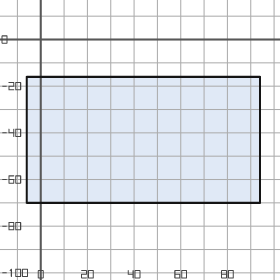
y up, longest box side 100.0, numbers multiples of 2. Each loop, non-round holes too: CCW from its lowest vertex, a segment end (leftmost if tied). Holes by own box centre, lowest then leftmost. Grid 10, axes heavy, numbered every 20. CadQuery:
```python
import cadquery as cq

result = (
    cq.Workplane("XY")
    .moveTo(-6.0, -70.0)
    .lineTo(94.0, -70.0)
    .lineTo(94.0, -16.0)
    .lineTo(-6.0, -16.0)
    .close()
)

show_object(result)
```